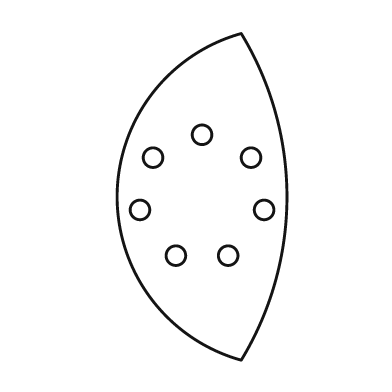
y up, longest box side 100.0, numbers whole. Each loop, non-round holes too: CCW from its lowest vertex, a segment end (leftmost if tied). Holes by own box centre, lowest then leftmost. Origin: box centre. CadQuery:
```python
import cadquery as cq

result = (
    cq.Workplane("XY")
    .moveTo(12.0, -50.0)
    .threePointArc((26.0, 0.0), (12.0, 50.0))
    .threePointArc((-26.0, 0.0), (12.0, -50.0))
    .close()
    .moveTo(-8.0, -18.0)
    .circle(3.0)
    .moveTo(8.0, -18.0)
    .circle(3.0)
    .moveTo(-19.0, -4.0)
    .circle(3.0)
    .moveTo(19.0, -4.0)
    .circle(3.0)
    .moveTo(-15.0, 12.0)
    .circle(3.0)
    .moveTo(15.0, 12.0)
    .circle(3.0)
    .moveTo(0.0, 19.0)
    .circle(3.0)
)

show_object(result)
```